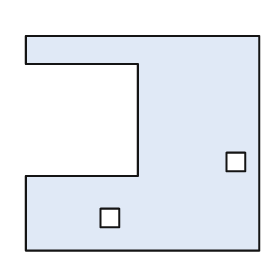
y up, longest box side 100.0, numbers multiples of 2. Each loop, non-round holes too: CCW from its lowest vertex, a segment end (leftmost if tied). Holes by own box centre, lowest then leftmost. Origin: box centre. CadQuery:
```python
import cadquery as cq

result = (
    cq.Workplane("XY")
    .moveTo(-50.0, -46.0)
    .lineTo(50.0, -46.0)
    .lineTo(50.0, 46.0)
    .lineTo(-50.0, 46.0)
    .lineTo(-50.0, 34.0)
    .lineTo(-2.0, 34.0)
    .lineTo(-2.0, -14.0)
    .lineTo(-50.0, -14.0)
    .close()
    .moveTo(-18.0, -36.0)
    .lineTo(-10.0, -36.0)
    .lineTo(-10.0, -28.0)
    .lineTo(-18.0, -28.0)
    .close()
    .moveTo(36.0, -12.0)
    .lineTo(44.0, -12.0)
    .lineTo(44.0, -4.0)
    .lineTo(36.0, -4.0)
    .close()
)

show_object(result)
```